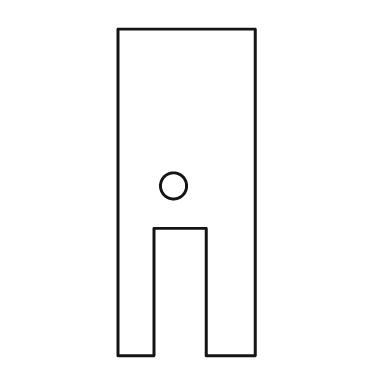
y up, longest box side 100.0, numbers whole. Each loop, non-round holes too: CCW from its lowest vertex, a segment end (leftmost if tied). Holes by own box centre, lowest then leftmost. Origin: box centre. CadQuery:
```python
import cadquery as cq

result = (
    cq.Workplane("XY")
    .moveTo(-21.0, -50.0)
    .lineTo(-10.0, -50.0)
    .lineTo(-10.0, -11.0)
    .lineTo(6.0, -11.0)
    .lineTo(6.0, -50.0)
    .lineTo(21.0, -50.0)
    .lineTo(21.0, 50.0)
    .lineTo(-21.0, 50.0)
    .close()
    .moveTo(-4.0, 2.0)
    .circle(4.0)
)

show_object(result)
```